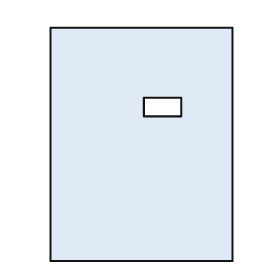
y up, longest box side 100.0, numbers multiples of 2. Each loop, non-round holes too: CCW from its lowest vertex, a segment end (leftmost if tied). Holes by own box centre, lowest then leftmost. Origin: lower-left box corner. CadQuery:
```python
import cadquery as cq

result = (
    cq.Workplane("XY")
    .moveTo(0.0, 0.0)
    .lineTo(78.0, 0.0)
    .lineTo(78.0, 100.0)
    .lineTo(0.0, 100.0)
    .close()
    .moveTo(40.0, 62.0)
    .lineTo(56.0, 62.0)
    .lineTo(56.0, 70.0)
    .lineTo(40.0, 70.0)
    .close()
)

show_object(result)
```